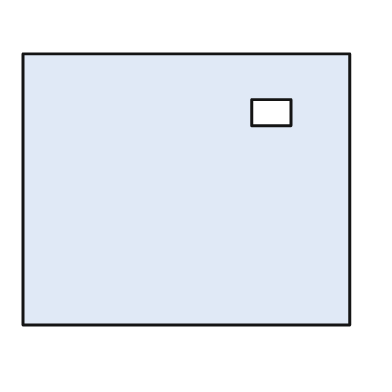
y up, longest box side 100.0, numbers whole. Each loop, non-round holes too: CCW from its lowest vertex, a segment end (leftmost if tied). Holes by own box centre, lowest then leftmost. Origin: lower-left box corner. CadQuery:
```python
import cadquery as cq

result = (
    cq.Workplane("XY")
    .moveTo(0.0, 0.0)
    .lineTo(100.0, 0.0)
    .lineTo(100.0, 83.0)
    .lineTo(0.0, 83.0)
    .close()
    .moveTo(70.0, 61.0)
    .lineTo(82.0, 61.0)
    .lineTo(82.0, 69.0)
    .lineTo(70.0, 69.0)
    .close()
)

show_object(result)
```